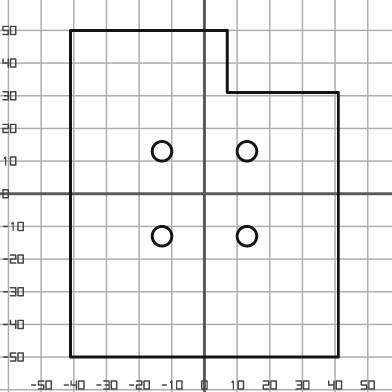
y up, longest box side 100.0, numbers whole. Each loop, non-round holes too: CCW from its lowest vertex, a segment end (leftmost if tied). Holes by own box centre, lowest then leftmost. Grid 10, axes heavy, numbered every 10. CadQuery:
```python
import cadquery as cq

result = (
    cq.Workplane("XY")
    .moveTo(-41.0, -50.0)
    .lineTo(41.0, -50.0)
    .lineTo(41.0, 31.0)
    .lineTo(7.0, 31.0)
    .lineTo(7.0, 50.0)
    .lineTo(-41.0, 50.0)
    .close()
    .moveTo(-13.0, -13.0)
    .circle(3.0)
    .moveTo(13.0, -13.0)
    .circle(3.0)
    .moveTo(-13.0, 13.0)
    .circle(3.0)
    .moveTo(13.0, 13.0)
    .circle(3.0)
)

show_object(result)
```